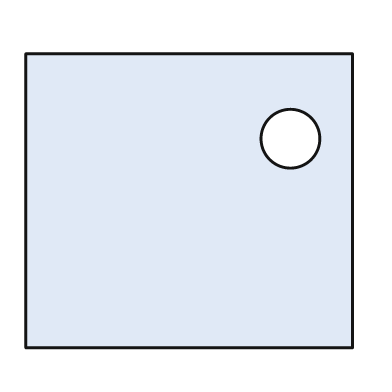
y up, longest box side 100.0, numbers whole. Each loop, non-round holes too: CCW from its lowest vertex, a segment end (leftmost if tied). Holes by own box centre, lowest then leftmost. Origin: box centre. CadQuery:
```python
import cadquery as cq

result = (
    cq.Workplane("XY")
    .moveTo(-50.0, -45.0)
    .lineTo(50.0, -45.0)
    .lineTo(50.0, 45.0)
    .lineTo(-50.0, 45.0)
    .close()
    .moveTo(31.0, 19.0)
    .circle(9.0)
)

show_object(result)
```